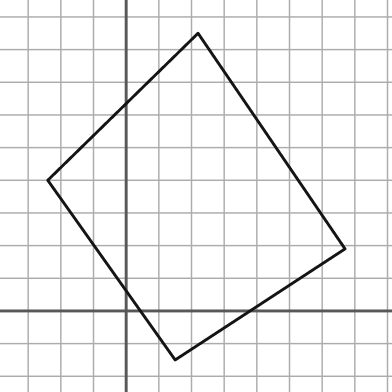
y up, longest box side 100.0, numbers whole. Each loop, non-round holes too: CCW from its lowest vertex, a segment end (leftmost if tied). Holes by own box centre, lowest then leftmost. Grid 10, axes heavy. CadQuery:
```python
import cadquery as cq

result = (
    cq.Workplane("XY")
    .moveTo(15.0, -15.0)
    .lineTo(67.0, 19.0)
    .lineTo(22.0, 85.0)
    .lineTo(-24.0, 40.0)
    .close()
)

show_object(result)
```